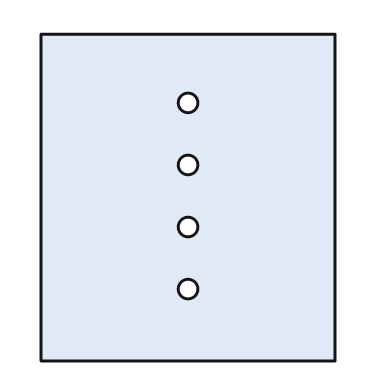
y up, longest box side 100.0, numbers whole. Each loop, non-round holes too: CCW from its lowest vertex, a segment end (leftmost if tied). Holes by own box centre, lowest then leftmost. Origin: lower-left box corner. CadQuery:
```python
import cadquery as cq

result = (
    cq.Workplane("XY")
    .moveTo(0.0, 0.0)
    .lineTo(90.0, 0.0)
    .lineTo(90.0, 100.0)
    .lineTo(0.0, 100.0)
    .close()
    .moveTo(45.0, 22.0)
    .circle(3.0)
    .moveTo(45.0, 41.0)
    .circle(3.0)
    .moveTo(45.0, 60.0)
    .circle(3.0)
    .moveTo(45.0, 79.0)
    .circle(3.0)
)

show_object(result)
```